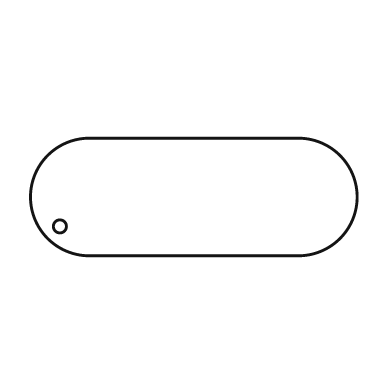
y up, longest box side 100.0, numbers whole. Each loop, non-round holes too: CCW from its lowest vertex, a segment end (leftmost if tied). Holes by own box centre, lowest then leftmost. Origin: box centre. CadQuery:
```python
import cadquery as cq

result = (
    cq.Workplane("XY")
    .moveTo(-32.0, -18.0)
    .lineTo(32.0, -18.0)
    .threePointArc((50.0, 0.0), (32.0, 18.0))
    .lineTo(-32.0, 18.0)
    .threePointArc((-50.0, 0.0), (-32.0, -18.0))
    .close()
    .moveTo(-41.0, -9.0)
    .circle(2.0)
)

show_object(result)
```